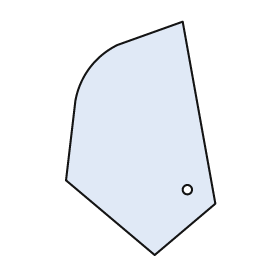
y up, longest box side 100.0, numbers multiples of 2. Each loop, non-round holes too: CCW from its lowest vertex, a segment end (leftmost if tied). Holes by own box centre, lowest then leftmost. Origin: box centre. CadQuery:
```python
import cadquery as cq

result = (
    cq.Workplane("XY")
    .moveTo(6.0, -50.0)
    .lineTo(32.0, -28.0)
    .lineTo(18.0, 50.0)
    .lineTo(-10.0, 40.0)
    .threePointArc((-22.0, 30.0), (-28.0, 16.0))
    .lineTo(-32.0, -18.0)
    .close()
    .moveTo(20.0, -22.0)
    .circle(2.0)
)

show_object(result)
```